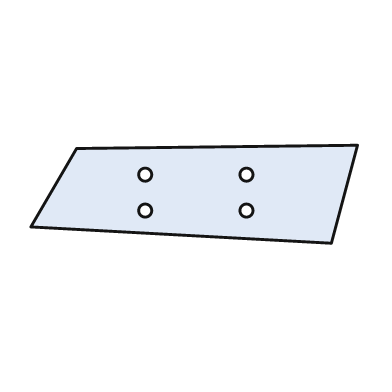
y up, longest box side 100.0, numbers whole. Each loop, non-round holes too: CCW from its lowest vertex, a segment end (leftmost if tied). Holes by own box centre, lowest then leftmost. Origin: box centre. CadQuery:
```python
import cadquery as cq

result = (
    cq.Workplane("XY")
    .moveTo(42.0, -15.0)
    .lineTo(50.0, 15.0)
    .lineTo(-36.0, 14.0)
    .lineTo(-50.0, -10.0)
    .close()
    .moveTo(-15.0, -5.0)
    .circle(2.0)
    .moveTo(16.0, -5.0)
    .circle(2.0)
    .moveTo(-15.0, 6.0)
    .circle(2.0)
    .moveTo(16.0, 6.0)
    .circle(2.0)
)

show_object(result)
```